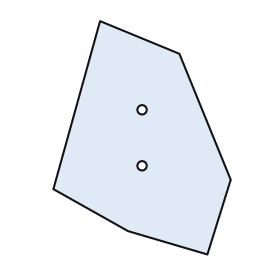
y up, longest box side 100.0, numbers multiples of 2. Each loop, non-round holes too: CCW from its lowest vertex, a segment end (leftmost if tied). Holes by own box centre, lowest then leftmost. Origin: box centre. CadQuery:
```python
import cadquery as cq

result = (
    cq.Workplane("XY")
    .moveTo(28.0, -50.0)
    .lineTo(38.0, -18.0)
    .lineTo(16.0, 36.0)
    .lineTo(-18.0, 50.0)
    .lineTo(-38.0, -22.0)
    .lineTo(-6.0, -40.0)
    .close()
    .moveTo(0.0, -12.0)
    .circle(2.0)
    .moveTo(0.0, 12.0)
    .circle(2.0)
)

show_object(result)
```